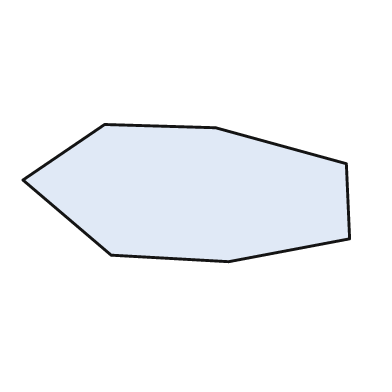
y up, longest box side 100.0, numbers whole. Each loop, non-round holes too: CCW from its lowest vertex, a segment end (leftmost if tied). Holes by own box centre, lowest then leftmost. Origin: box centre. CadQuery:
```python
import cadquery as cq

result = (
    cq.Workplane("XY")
    .moveTo(13.0, -21.0)
    .lineTo(50.0, -14.0)
    .lineTo(49.0, 9.0)
    .lineTo(9.0, 20.0)
    .lineTo(-25.0, 21.0)
    .lineTo(-50.0, 4.0)
    .lineTo(-23.0, -19.0)
    .close()
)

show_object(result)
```